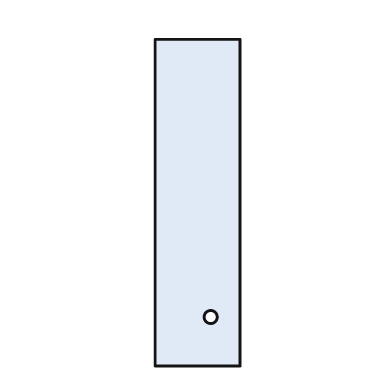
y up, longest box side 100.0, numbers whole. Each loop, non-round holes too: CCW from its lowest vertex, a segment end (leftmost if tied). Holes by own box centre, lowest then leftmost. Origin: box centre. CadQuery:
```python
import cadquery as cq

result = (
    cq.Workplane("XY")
    .moveTo(-13.0, -50.0)
    .lineTo(13.0, -50.0)
    .lineTo(13.0, 50.0)
    .lineTo(-13.0, 50.0)
    .close()
    .moveTo(4.0, -35.0)
    .circle(2.0)
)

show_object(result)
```